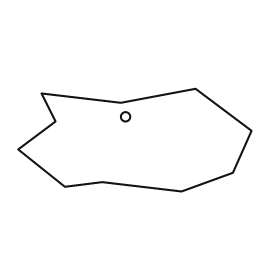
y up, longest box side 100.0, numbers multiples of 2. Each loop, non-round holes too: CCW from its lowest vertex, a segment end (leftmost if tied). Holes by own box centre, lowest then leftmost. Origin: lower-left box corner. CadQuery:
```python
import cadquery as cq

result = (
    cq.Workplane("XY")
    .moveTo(70.0, 0.0)
    .lineTo(92.0, 8.0)
    .lineTo(100.0, 26.0)
    .lineTo(76.0, 44.0)
    .lineTo(44.0, 38.0)
    .lineTo(10.0, 42.0)
    .lineTo(16.0, 30.0)
    .lineTo(0.0, 18.0)
    .lineTo(20.0, 2.0)
    .lineTo(36.0, 4.0)
    .close()
    .moveTo(46.0, 32.0)
    .circle(2.0)
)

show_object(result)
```